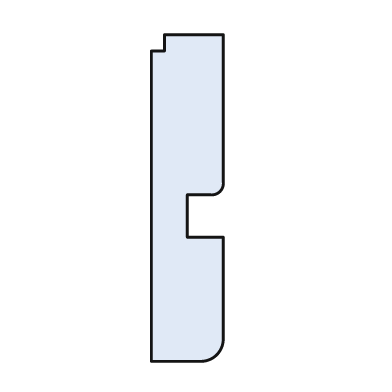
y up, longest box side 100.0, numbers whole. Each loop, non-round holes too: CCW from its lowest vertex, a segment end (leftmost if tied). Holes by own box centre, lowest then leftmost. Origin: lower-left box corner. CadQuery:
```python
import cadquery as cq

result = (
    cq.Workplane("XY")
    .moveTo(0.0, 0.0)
    .lineTo(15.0, 0.0)
    .threePointArc((20.0, 2.0), (22.0, 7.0))
    .lineTo(22.0, 38.0)
    .lineTo(11.0, 38.0)
    .lineTo(11.0, 51.0)
    .lineTo(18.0, 51.0)
    .threePointArc((21.0, 52.0), (22.0, 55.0))
    .lineTo(22.0, 100.0)
    .lineTo(4.0, 100.0)
    .lineTo(4.0, 95.0)
    .lineTo(0.0, 95.0)
    .close()
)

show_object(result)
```